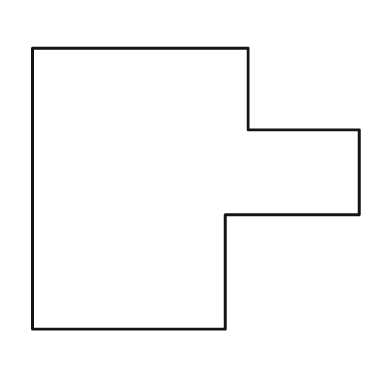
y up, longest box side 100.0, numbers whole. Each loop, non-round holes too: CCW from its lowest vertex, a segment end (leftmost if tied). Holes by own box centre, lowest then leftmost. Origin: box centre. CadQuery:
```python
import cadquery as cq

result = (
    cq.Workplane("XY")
    .moveTo(-50.0, -43.0)
    .lineTo(9.0, -43.0)
    .lineTo(9.0, -8.0)
    .lineTo(50.0, -8.0)
    .lineTo(50.0, 18.0)
    .lineTo(16.0, 18.0)
    .lineTo(16.0, 43.0)
    .lineTo(-50.0, 43.0)
    .close()
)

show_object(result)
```